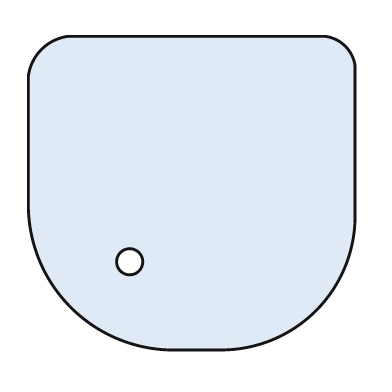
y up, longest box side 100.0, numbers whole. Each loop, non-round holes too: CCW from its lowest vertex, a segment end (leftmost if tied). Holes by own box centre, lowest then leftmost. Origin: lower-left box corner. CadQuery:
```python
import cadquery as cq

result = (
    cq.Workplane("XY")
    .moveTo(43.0, 0.0)
    .lineTo(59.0, 0.0)
    .threePointArc((88.0, 12.0), (100.0, 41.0))
    .lineTo(100.0, 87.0)
    .threePointArc((97.0, 93.0), (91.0, 96.0))
    .lineTo(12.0, 96.0)
    .threePointArc((4.0, 92.0), (0.0, 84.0))
    .lineTo(0.0, 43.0)
    .threePointArc((13.0, 13.0), (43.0, 0.0))
    .close()
    .moveTo(31.0, 27.0)
    .circle(4.0)
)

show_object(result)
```